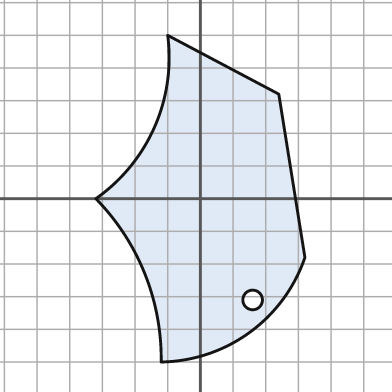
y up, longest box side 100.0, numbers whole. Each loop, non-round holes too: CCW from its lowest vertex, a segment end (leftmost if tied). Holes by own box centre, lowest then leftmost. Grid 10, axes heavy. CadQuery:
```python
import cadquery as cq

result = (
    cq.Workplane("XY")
    .moveTo(-12.0, -50.0)
    .threePointArc((15.0, -41.0), (32.0, -18.0))
    .lineTo(24.0, 32.0)
    .lineTo(-10.0, 50.0)
    .threePointArc((-14.0, 22.0), (-32.0, 0.0))
    .threePointArc((-17.0, -23.0), (-12.0, -50.0))
    .close()
    .moveTo(16.0, -31.0)
    .circle(3.0)
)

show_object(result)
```